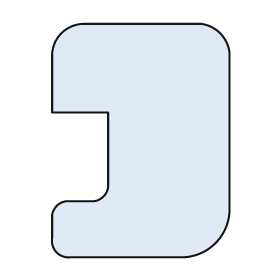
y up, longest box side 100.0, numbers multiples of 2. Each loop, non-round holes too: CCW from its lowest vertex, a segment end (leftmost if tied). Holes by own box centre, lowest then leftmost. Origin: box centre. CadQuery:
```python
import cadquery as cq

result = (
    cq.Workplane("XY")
    .moveTo(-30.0, -50.0)
    .lineTo(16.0, -50.0)
    .threePointArc((32.0, -44.0), (38.0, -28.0))
    .lineTo(38.0, 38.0)
    .threePointArc((34.0, 46.0), (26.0, 50.0))
    .lineTo(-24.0, 50.0)
    .threePointArc((-34.0, 46.0), (-38.0, 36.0))
    .lineTo(-38.0, 12.0)
    .lineTo(-14.0, 12.0)
    .lineTo(-14.0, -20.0)
    .threePointArc((-16.0, -24.0), (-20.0, -26.0))
    .lineTo(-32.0, -26.0)
    .threePointArc((-36.0, -28.0), (-38.0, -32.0))
    .lineTo(-38.0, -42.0)
    .threePointArc((-36.0, -48.0), (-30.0, -50.0))
    .close()
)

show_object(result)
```